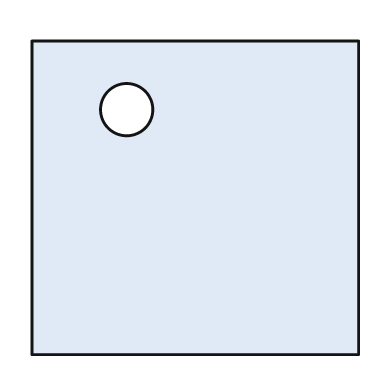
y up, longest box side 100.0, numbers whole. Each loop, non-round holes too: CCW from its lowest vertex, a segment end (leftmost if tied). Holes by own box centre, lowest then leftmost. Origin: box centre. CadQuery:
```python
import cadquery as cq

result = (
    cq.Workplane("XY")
    .moveTo(-50.0, -48.0)
    .lineTo(50.0, -48.0)
    .lineTo(50.0, 48.0)
    .lineTo(-50.0, 48.0)
    .close()
    .moveTo(-21.0, 27.0)
    .circle(8.0)
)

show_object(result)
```